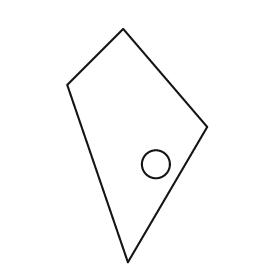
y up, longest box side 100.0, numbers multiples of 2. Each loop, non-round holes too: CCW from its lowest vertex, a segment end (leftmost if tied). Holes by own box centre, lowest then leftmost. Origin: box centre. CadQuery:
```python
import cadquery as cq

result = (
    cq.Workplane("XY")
    .moveTo(-4.0, -50.0)
    .lineTo(30.0, 8.0)
    .lineTo(-6.0, 50.0)
    .lineTo(-30.0, 26.0)
    .close()
    .moveTo(8.0, -8.0)
    .circle(6.0)
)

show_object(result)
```